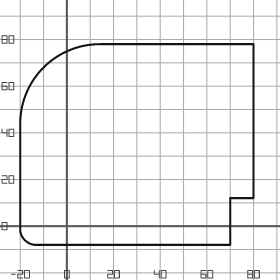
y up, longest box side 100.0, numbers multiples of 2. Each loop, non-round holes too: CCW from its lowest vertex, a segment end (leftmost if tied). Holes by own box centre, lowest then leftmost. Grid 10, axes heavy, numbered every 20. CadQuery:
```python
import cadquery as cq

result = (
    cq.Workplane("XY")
    .moveTo(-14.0, -8.0)
    .lineTo(70.0, -8.0)
    .lineTo(70.0, 12.0)
    .lineTo(80.0, 12.0)
    .lineTo(80.0, 78.0)
    .lineTo(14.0, 78.0)
    .threePointArc((-10.0, 68.0), (-20.0, 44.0))
    .lineTo(-20.0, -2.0)
    .threePointArc((-18.0, -6.0), (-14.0, -8.0))
    .close()
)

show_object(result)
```